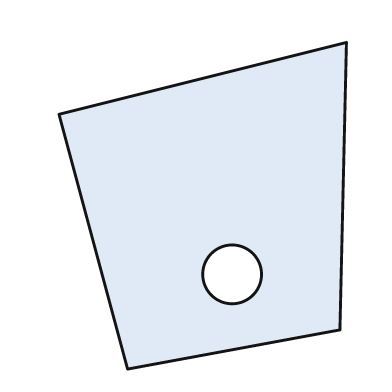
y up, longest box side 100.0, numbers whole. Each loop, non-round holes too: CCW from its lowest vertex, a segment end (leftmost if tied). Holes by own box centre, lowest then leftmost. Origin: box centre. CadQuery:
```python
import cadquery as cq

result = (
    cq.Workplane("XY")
    .moveTo(-23.0, -50.0)
    .lineTo(42.0, -38.0)
    .lineTo(44.0, 50.0)
    .lineTo(-44.0, 28.0)
    .close()
    .moveTo(9.0, -21.0)
    .circle(9.0)
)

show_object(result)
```